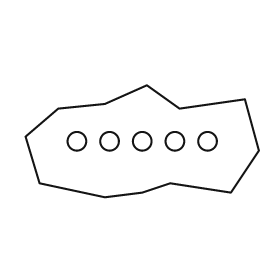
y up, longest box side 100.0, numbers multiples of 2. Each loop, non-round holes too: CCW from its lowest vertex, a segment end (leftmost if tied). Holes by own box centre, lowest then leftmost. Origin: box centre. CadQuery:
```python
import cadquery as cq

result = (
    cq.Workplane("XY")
    .moveTo(-16.0, -24.0)
    .lineTo(0.0, -22.0)
    .lineTo(12.0, -18.0)
    .lineTo(38.0, -22.0)
    .lineTo(50.0, -4.0)
    .lineTo(44.0, 18.0)
    .lineTo(16.0, 14.0)
    .lineTo(2.0, 24.0)
    .lineTo(-16.0, 16.0)
    .lineTo(-36.0, 14.0)
    .lineTo(-50.0, 2.0)
    .lineTo(-44.0, -18.0)
    .close()
    .moveTo(-28.0, 0.0)
    .circle(4.0)
    .moveTo(-14.0, 0.0)
    .circle(4.0)
    .moveTo(0.0, 0.0)
    .circle(4.0)
    .moveTo(14.0, 0.0)
    .circle(4.0)
    .moveTo(28.0, 0.0)
    .circle(4.0)
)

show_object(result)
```